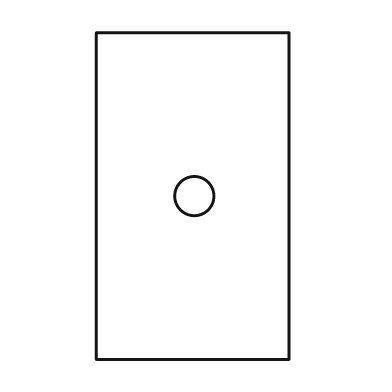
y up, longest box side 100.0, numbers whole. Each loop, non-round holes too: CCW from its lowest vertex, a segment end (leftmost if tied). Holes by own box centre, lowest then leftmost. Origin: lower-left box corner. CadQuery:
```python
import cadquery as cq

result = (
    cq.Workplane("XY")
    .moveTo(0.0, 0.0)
    .lineTo(59.0, 0.0)
    .lineTo(59.0, 100.0)
    .lineTo(0.0, 100.0)
    .close()
    .moveTo(30.0, 50.0)
    .circle(6.0)
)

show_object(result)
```